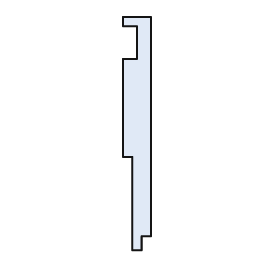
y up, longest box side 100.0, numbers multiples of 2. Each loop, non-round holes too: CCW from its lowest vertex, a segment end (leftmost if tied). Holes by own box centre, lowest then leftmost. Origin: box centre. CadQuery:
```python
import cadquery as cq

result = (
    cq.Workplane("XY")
    .moveTo(-2.0, -50.0)
    .lineTo(2.0, -50.0)
    .lineTo(2.0, -44.0)
    .lineTo(6.0, -44.0)
    .lineTo(6.0, 50.0)
    .lineTo(-6.0, 50.0)
    .lineTo(-6.0, 46.0)
    .lineTo(0.0, 46.0)
    .lineTo(0.0, 32.0)
    .lineTo(-6.0, 32.0)
    .lineTo(-6.0, -10.0)
    .lineTo(-2.0, -10.0)
    .close()
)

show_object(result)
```